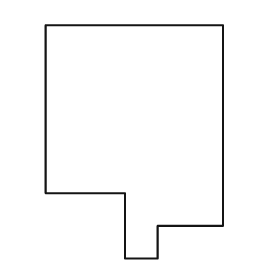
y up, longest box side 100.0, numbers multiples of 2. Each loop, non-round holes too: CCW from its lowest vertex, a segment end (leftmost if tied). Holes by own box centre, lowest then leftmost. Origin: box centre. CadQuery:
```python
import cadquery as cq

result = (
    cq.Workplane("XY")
    .moveTo(-4.0, -50.0)
    .lineTo(10.0, -50.0)
    .lineTo(10.0, -36.0)
    .lineTo(38.0, -36.0)
    .lineTo(38.0, 50.0)
    .lineTo(-38.0, 50.0)
    .lineTo(-38.0, -22.0)
    .lineTo(-4.0, -22.0)
    .close()
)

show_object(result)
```